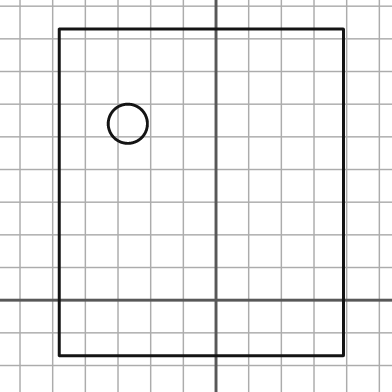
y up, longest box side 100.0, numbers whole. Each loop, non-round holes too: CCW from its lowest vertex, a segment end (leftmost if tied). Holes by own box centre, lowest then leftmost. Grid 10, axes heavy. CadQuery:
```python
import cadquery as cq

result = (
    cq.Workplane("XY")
    .moveTo(-48.0, -17.0)
    .lineTo(39.0, -17.0)
    .lineTo(39.0, 83.0)
    .lineTo(-48.0, 83.0)
    .close()
    .moveTo(-27.0, 54.0)
    .circle(6.0)
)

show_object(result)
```